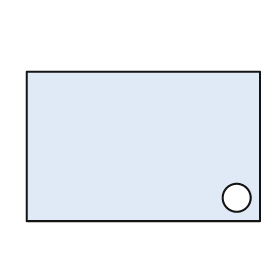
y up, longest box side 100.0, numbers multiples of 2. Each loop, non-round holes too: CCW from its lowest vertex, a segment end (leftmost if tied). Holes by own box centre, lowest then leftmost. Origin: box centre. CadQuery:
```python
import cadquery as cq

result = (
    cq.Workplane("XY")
    .moveTo(-50.0, -32.0)
    .lineTo(50.0, -32.0)
    .lineTo(50.0, 32.0)
    .lineTo(-50.0, 32.0)
    .close()
    .moveTo(40.0, -22.0)
    .circle(6.0)
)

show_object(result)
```